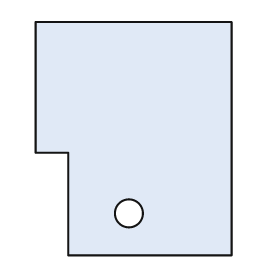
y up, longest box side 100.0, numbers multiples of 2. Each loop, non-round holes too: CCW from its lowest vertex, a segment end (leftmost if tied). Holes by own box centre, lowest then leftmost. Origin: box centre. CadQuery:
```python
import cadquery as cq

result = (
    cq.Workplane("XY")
    .moveTo(-28.0, -50.0)
    .lineTo(42.0, -50.0)
    .lineTo(42.0, 50.0)
    .lineTo(-42.0, 50.0)
    .lineTo(-42.0, -6.0)
    .lineTo(-28.0, -6.0)
    .close()
    .moveTo(-2.0, -32.0)
    .circle(6.0)
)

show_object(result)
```